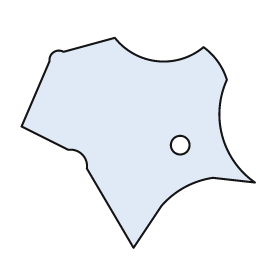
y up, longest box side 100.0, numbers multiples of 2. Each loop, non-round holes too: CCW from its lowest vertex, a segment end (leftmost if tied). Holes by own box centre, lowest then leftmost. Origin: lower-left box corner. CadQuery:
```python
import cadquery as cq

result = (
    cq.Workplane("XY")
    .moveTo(48.0, 0.0)
    .lineTo(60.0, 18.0)
    .threePointArc((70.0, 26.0), (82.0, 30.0))
    .lineTo(100.0, 28.0)
    .threePointArc((86.0, 48.0), (88.0, 72.0))
    .threePointArc((84.0, 80.0), (78.0, 86.0))
    .threePointArc((58.0, 80.0), (40.0, 90.0))
    .lineTo(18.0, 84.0)
    .threePointArc((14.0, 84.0), (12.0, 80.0))
    .lineTo(0.0, 52.0)
    .lineTo(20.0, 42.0)
    .threePointArc((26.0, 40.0), (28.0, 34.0))
    .close()
    .moveTo(68.0, 44.0)
    .circle(4.0)
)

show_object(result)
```